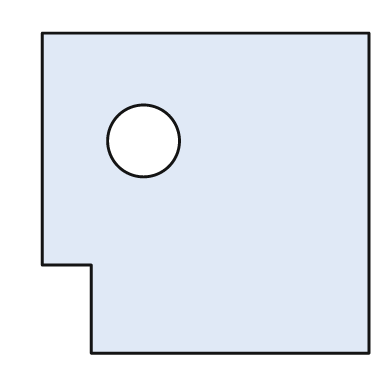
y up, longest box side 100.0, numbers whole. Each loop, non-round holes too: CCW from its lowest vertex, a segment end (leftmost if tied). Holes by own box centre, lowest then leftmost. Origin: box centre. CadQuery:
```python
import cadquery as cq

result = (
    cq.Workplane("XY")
    .moveTo(-35.0, -49.0)
    .lineTo(50.0, -49.0)
    .lineTo(50.0, 49.0)
    .lineTo(-50.0, 49.0)
    .lineTo(-50.0, -22.0)
    .lineTo(-35.0, -22.0)
    .close()
    .moveTo(-19.0, 16.0)
    .circle(11.0)
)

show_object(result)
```